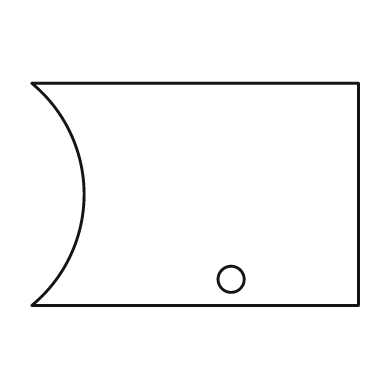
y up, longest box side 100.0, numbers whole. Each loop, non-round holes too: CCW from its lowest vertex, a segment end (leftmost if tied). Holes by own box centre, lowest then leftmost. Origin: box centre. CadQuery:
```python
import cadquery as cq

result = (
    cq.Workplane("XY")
    .moveTo(-50.0, -34.0)
    .lineTo(50.0, -34.0)
    .lineTo(50.0, 34.0)
    .lineTo(-50.0, 34.0)
    .threePointArc((-34.0, 0.0), (-50.0, -34.0))
    .close()
    .moveTo(11.0, -26.0)
    .circle(4.0)
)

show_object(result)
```